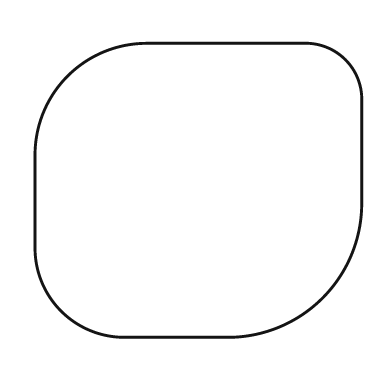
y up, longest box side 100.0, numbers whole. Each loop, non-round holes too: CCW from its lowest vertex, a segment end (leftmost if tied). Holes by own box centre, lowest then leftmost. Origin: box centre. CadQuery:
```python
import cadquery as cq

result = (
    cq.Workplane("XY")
    .moveTo(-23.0, -45.0)
    .lineTo(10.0, -45.0)
    .threePointArc((38.0, -33.0), (50.0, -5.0))
    .lineTo(50.0, 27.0)
    .threePointArc((45.0, 40.0), (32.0, 45.0))
    .lineTo(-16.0, 45.0)
    .threePointArc((-40.0, 35.0), (-50.0, 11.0))
    .lineTo(-50.0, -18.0)
    .threePointArc((-42.0, -37.0), (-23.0, -45.0))
    .close()
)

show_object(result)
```